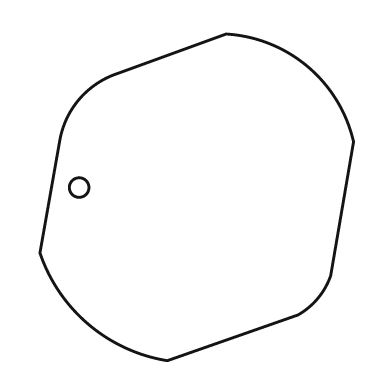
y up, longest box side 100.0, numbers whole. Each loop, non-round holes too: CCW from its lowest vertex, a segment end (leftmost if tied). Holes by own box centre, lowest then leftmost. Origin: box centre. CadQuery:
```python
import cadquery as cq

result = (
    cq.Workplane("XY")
    .moveTo(-9.0, -50.0)
    .lineTo(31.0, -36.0)
    .threePointArc((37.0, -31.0), (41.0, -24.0))
    .lineTo(48.0, 17.0)
    .threePointArc((34.0, 40.0), (9.0, 50.0))
    .lineTo(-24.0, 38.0)
    .threePointArc((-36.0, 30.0), (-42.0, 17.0))
    .lineTo(-48.0, -17.0)
    .threePointArc((-33.0, -39.0), (-9.0, -50.0))
    .close()
    .moveTo(-36.0, 3.0)
    .circle(3.0)
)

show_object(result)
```